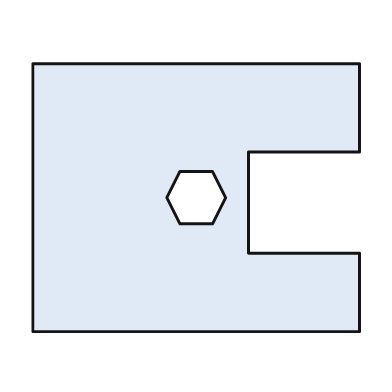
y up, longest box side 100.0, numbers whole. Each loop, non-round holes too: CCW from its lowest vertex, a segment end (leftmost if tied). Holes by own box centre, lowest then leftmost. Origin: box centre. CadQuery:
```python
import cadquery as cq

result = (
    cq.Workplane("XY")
    .moveTo(-50.0, -41.0)
    .lineTo(50.0, -41.0)
    .lineTo(50.0, -17.0)
    .lineTo(16.0, -17.0)
    .lineTo(16.0, 14.0)
    .lineTo(50.0, 14.0)
    .lineTo(50.0, 41.0)
    .lineTo(-50.0, 41.0)
    .close()
    .moveTo(-5.0, -8.0)
    .lineTo(5.0, -8.0)
    .lineTo(9.0, 0.0)
    .lineTo(5.0, 8.0)
    .lineTo(-5.0, 8.0)
    .lineTo(-9.0, 0.0)
    .close()
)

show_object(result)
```